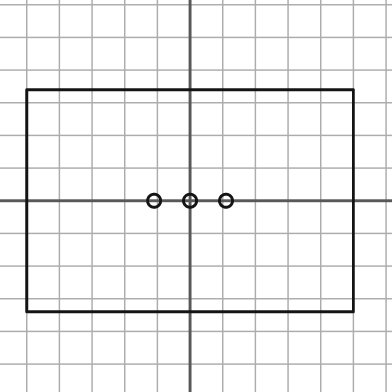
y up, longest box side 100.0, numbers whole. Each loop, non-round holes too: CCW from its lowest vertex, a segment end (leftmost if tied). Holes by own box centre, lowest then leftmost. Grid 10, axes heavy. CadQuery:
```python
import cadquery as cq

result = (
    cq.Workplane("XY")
    .moveTo(-50.0, -34.0)
    .lineTo(50.0, -34.0)
    .lineTo(50.0, 34.0)
    .lineTo(-50.0, 34.0)
    .close()
    .moveTo(-11.0, 0.0)
    .circle(2.0)
    .moveTo(0.0, 0.0)
    .circle(2.0)
    .moveTo(11.0, 0.0)
    .circle(2.0)
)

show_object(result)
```